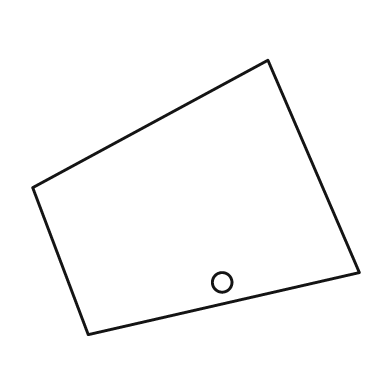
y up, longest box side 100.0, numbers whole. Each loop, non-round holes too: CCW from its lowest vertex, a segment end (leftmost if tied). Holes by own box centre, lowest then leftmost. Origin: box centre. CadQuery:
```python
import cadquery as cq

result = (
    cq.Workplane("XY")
    .moveTo(-33.0, -42.0)
    .lineTo(50.0, -23.0)
    .lineTo(22.0, 42.0)
    .lineTo(-50.0, 3.0)
    .close()
    .moveTo(8.0, -26.0)
    .circle(3.0)
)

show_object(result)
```